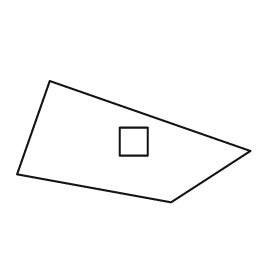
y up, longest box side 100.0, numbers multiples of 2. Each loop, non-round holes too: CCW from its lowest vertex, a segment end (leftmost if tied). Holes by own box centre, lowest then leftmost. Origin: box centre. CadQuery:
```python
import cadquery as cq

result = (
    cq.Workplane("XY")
    .moveTo(16.0, -26.0)
    .lineTo(50.0, -4.0)
    .lineTo(-36.0, 26.0)
    .lineTo(-50.0, -14.0)
    .close()
    .moveTo(-6.0, -6.0)
    .lineTo(6.0, -6.0)
    .lineTo(6.0, 6.0)
    .lineTo(-6.0, 6.0)
    .close()
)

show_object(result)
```